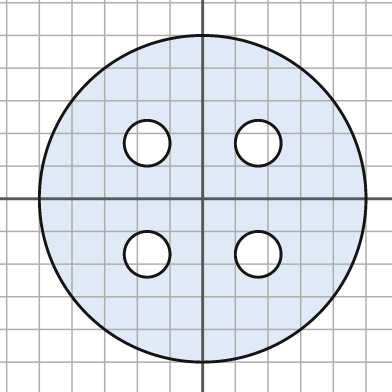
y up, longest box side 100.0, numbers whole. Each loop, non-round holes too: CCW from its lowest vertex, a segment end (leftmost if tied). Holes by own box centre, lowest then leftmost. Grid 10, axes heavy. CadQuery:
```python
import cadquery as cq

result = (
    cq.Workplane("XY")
    .moveTo(0.0, 0.0)
    .circle(50.0)
    .moveTo(-17.0, -17.0)
    .circle(7.0)
    .moveTo(17.0, -17.0)
    .circle(7.0)
    .moveTo(-17.0, 17.0)
    .circle(7.0)
    .moveTo(17.0, 17.0)
    .circle(7.0)
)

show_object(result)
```